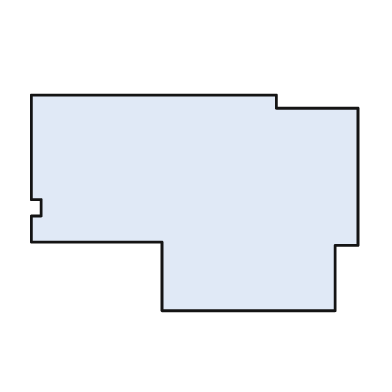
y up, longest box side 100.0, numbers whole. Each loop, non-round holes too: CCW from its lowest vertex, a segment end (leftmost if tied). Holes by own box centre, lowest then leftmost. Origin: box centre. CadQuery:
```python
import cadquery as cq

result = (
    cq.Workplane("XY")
    .moveTo(-10.0, -33.0)
    .lineTo(43.0, -33.0)
    .lineTo(43.0, -13.0)
    .lineTo(50.0, -13.0)
    .lineTo(50.0, 29.0)
    .lineTo(25.0, 29.0)
    .lineTo(25.0, 33.0)
    .lineTo(-50.0, 33.0)
    .lineTo(-50.0, 1.0)
    .lineTo(-47.0, 1.0)
    .lineTo(-47.0, -4.0)
    .lineTo(-50.0, -4.0)
    .lineTo(-50.0, -12.0)
    .lineTo(-10.0, -12.0)
    .close()
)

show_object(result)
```